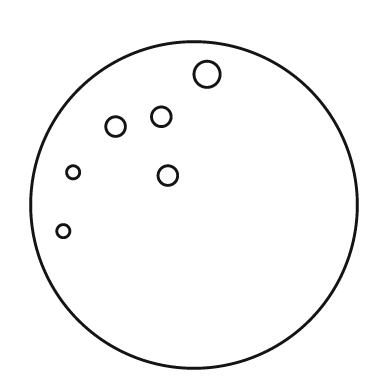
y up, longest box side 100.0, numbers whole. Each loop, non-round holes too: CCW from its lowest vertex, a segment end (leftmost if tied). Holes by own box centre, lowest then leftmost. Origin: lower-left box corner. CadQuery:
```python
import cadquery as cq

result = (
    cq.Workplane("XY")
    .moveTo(50.0, 50.0)
    .circle(50.0)
    .moveTo(10.0, 42.0)
    .circle(2.0)
    .moveTo(42.0, 59.0)
    .circle(3.0)
    .moveTo(13.0, 60.0)
    .circle(2.0)
    .moveTo(26.0, 74.0)
    .circle(3.0)
    .moveTo(40.0, 77.0)
    .circle(3.0)
    .moveTo(54.0, 90.0)
    .circle(4.0)
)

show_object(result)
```